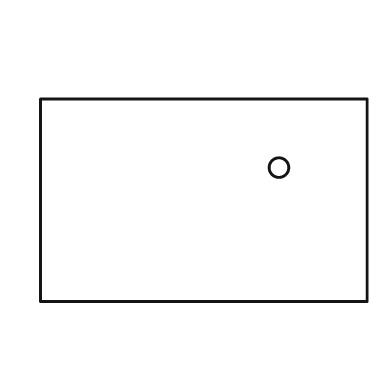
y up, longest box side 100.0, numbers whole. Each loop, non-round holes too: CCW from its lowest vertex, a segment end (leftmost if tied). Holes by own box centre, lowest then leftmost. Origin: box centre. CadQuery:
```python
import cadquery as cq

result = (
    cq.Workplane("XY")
    .moveTo(-50.0, -31.0)
    .lineTo(50.0, -31.0)
    .lineTo(50.0, 31.0)
    .lineTo(-50.0, 31.0)
    .close()
    .moveTo(23.0, 10.0)
    .circle(3.0)
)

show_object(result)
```